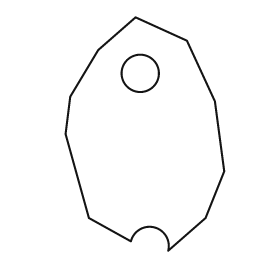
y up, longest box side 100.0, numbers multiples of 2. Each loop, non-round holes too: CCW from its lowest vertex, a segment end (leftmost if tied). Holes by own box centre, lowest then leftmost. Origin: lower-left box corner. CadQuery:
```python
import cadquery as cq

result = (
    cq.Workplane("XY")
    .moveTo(44.0, 0.0)
    .lineTo(60.0, 14.0)
    .lineTo(68.0, 34.0)
    .lineTo(64.0, 64.0)
    .lineTo(52.0, 90.0)
    .lineTo(30.0, 100.0)
    .lineTo(14.0, 86.0)
    .lineTo(2.0, 66.0)
    .lineTo(0.0, 50.0)
    .lineTo(10.0, 14.0)
    .lineTo(28.0, 4.0)
    .threePointArc((38.0, 10.0), (44.0, 0.0))
    .close()
    .moveTo(32.0, 76.0)
    .circle(8.0)
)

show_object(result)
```